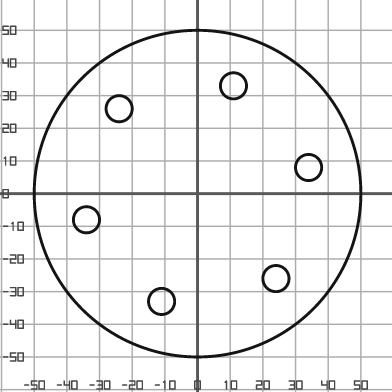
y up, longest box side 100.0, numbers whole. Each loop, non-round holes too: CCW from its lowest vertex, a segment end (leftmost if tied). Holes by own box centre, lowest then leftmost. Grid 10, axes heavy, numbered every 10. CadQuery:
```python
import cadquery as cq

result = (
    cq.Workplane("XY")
    .moveTo(0.0, 0.0)
    .circle(50.0)
    .moveTo(-11.0, -33.0)
    .circle(4.0)
    .moveTo(24.0, -26.0)
    .circle(4.0)
    .moveTo(-34.0, -8.0)
    .circle(4.0)
    .moveTo(34.0, 8.0)
    .circle(4.0)
    .moveTo(-24.0, 26.0)
    .circle(4.0)
    .moveTo(11.0, 33.0)
    .circle(4.0)
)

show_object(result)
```